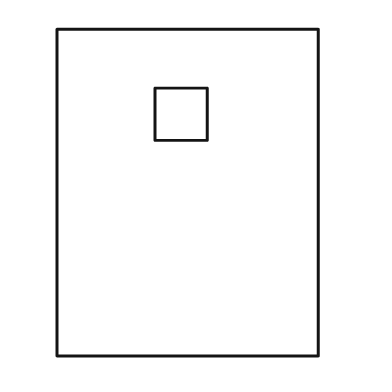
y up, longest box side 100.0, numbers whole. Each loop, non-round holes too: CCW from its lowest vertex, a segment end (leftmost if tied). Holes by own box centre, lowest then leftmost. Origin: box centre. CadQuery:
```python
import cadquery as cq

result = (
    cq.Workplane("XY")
    .moveTo(-40.0, -50.0)
    .lineTo(40.0, -50.0)
    .lineTo(40.0, 50.0)
    .lineTo(-40.0, 50.0)
    .close()
    .moveTo(-10.0, 16.0)
    .lineTo(6.0, 16.0)
    .lineTo(6.0, 32.0)
    .lineTo(-10.0, 32.0)
    .close()
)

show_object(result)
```